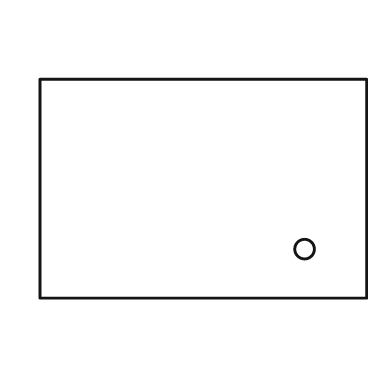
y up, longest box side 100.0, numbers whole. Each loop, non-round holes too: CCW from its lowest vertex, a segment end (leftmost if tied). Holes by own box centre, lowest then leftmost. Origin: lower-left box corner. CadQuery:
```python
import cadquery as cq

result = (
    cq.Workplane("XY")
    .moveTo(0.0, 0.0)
    .lineTo(100.0, 0.0)
    .lineTo(100.0, 67.0)
    .lineTo(0.0, 67.0)
    .close()
    .moveTo(81.0, 15.0)
    .circle(3.0)
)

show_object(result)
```